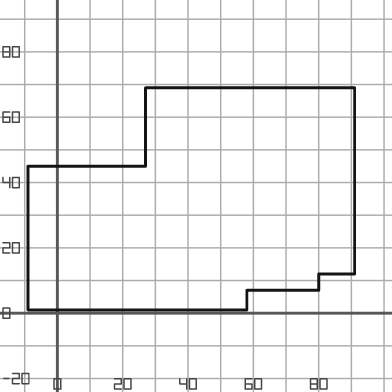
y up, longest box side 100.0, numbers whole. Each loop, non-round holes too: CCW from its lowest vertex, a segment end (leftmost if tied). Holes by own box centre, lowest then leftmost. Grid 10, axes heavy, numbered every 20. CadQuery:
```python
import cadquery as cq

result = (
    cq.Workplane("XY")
    .moveTo(-9.0, 1.0)
    .lineTo(58.0, 1.0)
    .lineTo(58.0, 7.0)
    .lineTo(80.0, 7.0)
    .lineTo(80.0, 12.0)
    .lineTo(91.0, 12.0)
    .lineTo(91.0, 69.0)
    .lineTo(27.0, 69.0)
    .lineTo(27.0, 45.0)
    .lineTo(-9.0, 45.0)
    .close()
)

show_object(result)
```